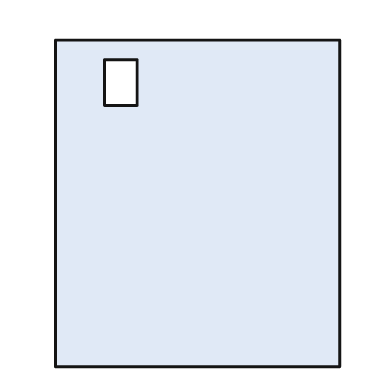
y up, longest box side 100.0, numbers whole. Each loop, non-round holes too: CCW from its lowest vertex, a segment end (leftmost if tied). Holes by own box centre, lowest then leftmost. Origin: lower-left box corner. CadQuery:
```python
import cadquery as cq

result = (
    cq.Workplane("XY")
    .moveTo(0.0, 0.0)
    .lineTo(87.0, 0.0)
    .lineTo(87.0, 100.0)
    .lineTo(0.0, 100.0)
    .close()
    .moveTo(15.0, 80.0)
    .lineTo(25.0, 80.0)
    .lineTo(25.0, 94.0)
    .lineTo(15.0, 94.0)
    .close()
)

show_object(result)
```